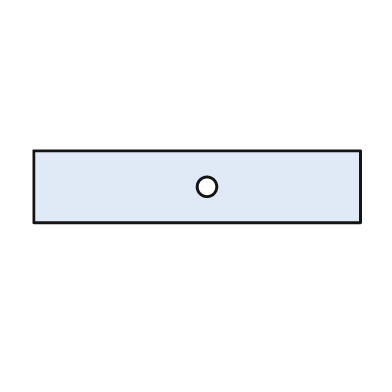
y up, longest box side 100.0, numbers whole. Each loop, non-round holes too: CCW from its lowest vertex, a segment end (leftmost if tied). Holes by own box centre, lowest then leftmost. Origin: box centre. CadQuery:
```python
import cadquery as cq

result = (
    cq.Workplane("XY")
    .moveTo(-50.0, -11.0)
    .lineTo(50.0, -11.0)
    .lineTo(50.0, 11.0)
    .lineTo(-50.0, 11.0)
    .close()
    .moveTo(3.0, 0.0)
    .circle(3.0)
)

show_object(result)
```